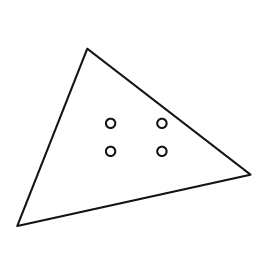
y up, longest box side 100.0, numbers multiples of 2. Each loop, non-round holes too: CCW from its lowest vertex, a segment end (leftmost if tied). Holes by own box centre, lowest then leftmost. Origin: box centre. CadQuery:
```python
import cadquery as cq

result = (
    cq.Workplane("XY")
    .moveTo(-50.0, -38.0)
    .lineTo(50.0, -16.0)
    .lineTo(-20.0, 38.0)
    .close()
    .moveTo(-10.0, -6.0)
    .circle(2.0)
    .moveTo(12.0, -6.0)
    .circle(2.0)
    .moveTo(-10.0, 6.0)
    .circle(2.0)
    .moveTo(12.0, 6.0)
    .circle(2.0)
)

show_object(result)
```